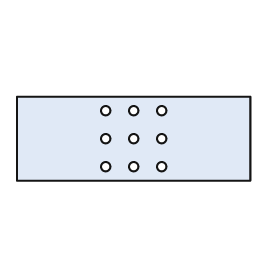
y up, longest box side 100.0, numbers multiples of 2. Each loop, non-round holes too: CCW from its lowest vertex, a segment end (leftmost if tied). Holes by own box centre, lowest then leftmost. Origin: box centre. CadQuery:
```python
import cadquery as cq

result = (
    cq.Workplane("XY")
    .moveTo(-50.0, -18.0)
    .lineTo(50.0, -18.0)
    .lineTo(50.0, 18.0)
    .lineTo(-50.0, 18.0)
    .close()
    .moveTo(-12.0, -12.0)
    .circle(2.0)
    .moveTo(0.0, -12.0)
    .circle(2.0)
    .moveTo(12.0, -12.0)
    .circle(2.0)
    .moveTo(-12.0, 0.0)
    .circle(2.0)
    .moveTo(0.0, 0.0)
    .circle(2.0)
    .moveTo(12.0, 0.0)
    .circle(2.0)
    .moveTo(-12.0, 12.0)
    .circle(2.0)
    .moveTo(0.0, 12.0)
    .circle(2.0)
    .moveTo(12.0, 12.0)
    .circle(2.0)
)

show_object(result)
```